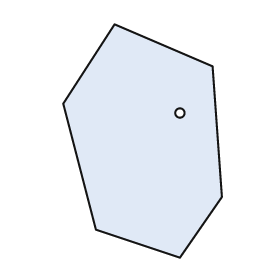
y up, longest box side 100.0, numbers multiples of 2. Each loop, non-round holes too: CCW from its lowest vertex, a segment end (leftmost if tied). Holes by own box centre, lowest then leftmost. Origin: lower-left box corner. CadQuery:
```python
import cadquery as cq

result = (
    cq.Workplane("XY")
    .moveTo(50.0, 0.0)
    .lineTo(68.0, 26.0)
    .lineTo(64.0, 82.0)
    .lineTo(22.0, 100.0)
    .lineTo(0.0, 66.0)
    .lineTo(14.0, 12.0)
    .close()
    .moveTo(50.0, 62.0)
    .circle(2.0)
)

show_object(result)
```